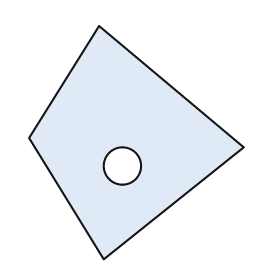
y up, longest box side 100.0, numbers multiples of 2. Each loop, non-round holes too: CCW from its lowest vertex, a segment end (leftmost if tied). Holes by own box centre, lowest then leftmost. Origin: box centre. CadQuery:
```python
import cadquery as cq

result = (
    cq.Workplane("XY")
    .moveTo(-14.0, -50.0)
    .lineTo(46.0, -2.0)
    .lineTo(-16.0, 50.0)
    .lineTo(-46.0, 2.0)
    .close()
    .moveTo(-6.0, -10.0)
    .circle(8.0)
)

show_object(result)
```